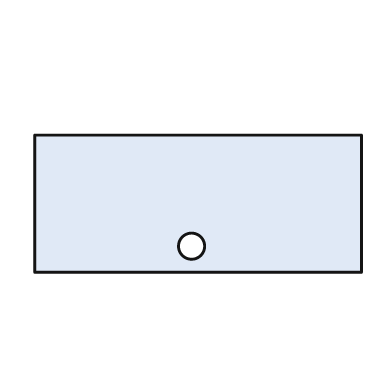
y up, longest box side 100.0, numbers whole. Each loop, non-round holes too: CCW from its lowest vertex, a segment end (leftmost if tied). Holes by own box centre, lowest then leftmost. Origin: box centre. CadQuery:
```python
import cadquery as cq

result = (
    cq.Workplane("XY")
    .moveTo(-50.0, -21.0)
    .lineTo(50.0, -21.0)
    .lineTo(50.0, 21.0)
    .lineTo(-50.0, 21.0)
    .close()
    .moveTo(-2.0, -13.0)
    .circle(4.0)
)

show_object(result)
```